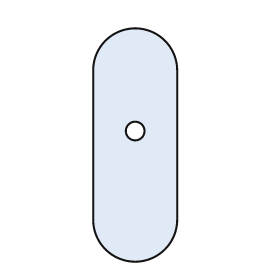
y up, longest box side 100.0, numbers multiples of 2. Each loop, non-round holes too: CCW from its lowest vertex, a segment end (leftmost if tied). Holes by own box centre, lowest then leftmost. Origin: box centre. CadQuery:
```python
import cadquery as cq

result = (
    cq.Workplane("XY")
    .moveTo(-18.0, -32.0)
    .threePointArc((0.0, -50.0), (18.0, -32.0))
    .lineTo(18.0, 32.0)
    .threePointArc((0.0, 50.0), (-18.0, 32.0))
    .close()
    .moveTo(0.0, 6.0)
    .circle(4.0)
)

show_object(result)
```